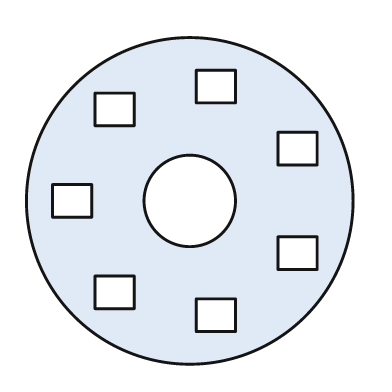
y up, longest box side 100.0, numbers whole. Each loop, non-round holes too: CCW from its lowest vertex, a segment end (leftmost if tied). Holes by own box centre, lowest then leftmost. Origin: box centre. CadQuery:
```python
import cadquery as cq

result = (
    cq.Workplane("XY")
    .moveTo(0.0, 0.0)
    .circle(50.0)
    .moveTo(2.0, -40.0)
    .lineTo(14.0, -40.0)
    .lineTo(14.0, -30.0)
    .lineTo(2.0, -30.0)
    .close()
    .moveTo(-29.0, -33.0)
    .lineTo(-17.0, -33.0)
    .lineTo(-17.0, -23.0)
    .lineTo(-29.0, -23.0)
    .close()
    .moveTo(27.0, -21.0)
    .lineTo(39.0, -21.0)
    .lineTo(39.0, -11.0)
    .lineTo(27.0, -11.0)
    .close()
    .moveTo(-42.0, -5.0)
    .lineTo(-30.0, -5.0)
    .lineTo(-30.0, 5.0)
    .lineTo(-42.0, 5.0)
    .close()
    .moveTo(0.0, 0.0)
    .circle(14.0)
    .moveTo(27.0, 11.0)
    .lineTo(39.0, 11.0)
    .lineTo(39.0, 21.0)
    .lineTo(27.0, 21.0)
    .close()
    .moveTo(-29.0, 23.0)
    .lineTo(-17.0, 23.0)
    .lineTo(-17.0, 33.0)
    .lineTo(-29.0, 33.0)
    .close()
    .moveTo(2.0, 30.0)
    .lineTo(14.0, 30.0)
    .lineTo(14.0, 40.0)
    .lineTo(2.0, 40.0)
    .close()
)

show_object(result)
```